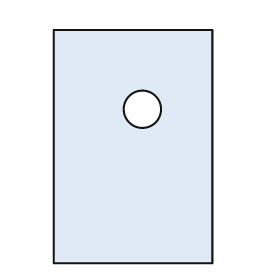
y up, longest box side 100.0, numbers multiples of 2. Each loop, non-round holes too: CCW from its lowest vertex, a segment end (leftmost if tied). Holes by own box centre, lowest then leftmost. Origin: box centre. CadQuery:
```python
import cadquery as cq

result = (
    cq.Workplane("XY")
    .moveTo(-34.0, -50.0)
    .lineTo(34.0, -50.0)
    .lineTo(34.0, 50.0)
    .lineTo(-34.0, 50.0)
    .close()
    .moveTo(4.0, 16.0)
    .circle(8.0)
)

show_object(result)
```